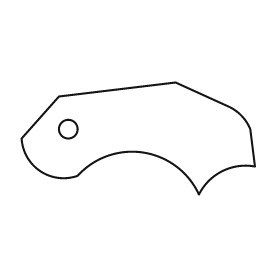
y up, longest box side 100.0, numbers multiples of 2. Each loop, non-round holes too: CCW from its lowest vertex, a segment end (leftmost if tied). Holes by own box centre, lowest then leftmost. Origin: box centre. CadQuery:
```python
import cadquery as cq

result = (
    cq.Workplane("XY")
    .moveTo(26.0, -24.0)
    .threePointArc((36.0, -14.0), (50.0, -12.0))
    .lineTo(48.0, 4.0)
    .threePointArc((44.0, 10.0), (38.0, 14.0))
    .lineTo(16.0, 24.0)
    .lineTo(-34.0, 18.0)
    .lineTo(-50.0, 0.0)
    .threePointArc((-42.0, -14.0), (-26.0, -16.0))
    .threePointArc((2.0, -6.0), (26.0, -24.0))
    .close()
    .moveTo(-30.0, 4.0)
    .circle(4.0)
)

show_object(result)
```